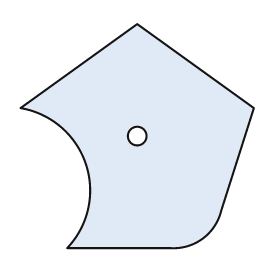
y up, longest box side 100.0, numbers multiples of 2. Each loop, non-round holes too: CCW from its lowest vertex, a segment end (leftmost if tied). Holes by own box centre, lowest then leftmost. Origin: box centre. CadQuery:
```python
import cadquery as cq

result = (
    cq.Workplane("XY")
    .moveTo(-30.0, -48.0)
    .lineTo(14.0, -48.0)
    .threePointArc((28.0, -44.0), (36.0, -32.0))
    .lineTo(50.0, 12.0)
    .lineTo(0.0, 48.0)
    .lineTo(-50.0, 12.0)
    .threePointArc((-22.0, -12.0), (-30.0, -48.0))
    .close()
    .moveTo(0.0, 0.0)
    .circle(4.0)
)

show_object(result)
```